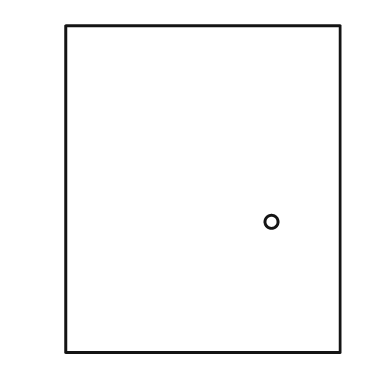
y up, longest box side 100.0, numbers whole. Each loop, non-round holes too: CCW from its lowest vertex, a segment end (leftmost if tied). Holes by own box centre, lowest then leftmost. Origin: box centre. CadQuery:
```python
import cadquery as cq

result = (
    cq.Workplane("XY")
    .moveTo(-42.0, -50.0)
    .lineTo(42.0, -50.0)
    .lineTo(42.0, 50.0)
    .lineTo(-42.0, 50.0)
    .close()
    .moveTo(21.0, -10.0)
    .circle(2.0)
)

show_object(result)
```